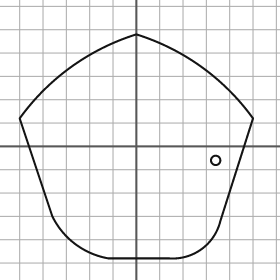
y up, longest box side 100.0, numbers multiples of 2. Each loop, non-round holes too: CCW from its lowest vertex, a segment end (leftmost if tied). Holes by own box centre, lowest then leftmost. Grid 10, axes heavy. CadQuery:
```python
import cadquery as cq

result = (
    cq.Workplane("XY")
    .moveTo(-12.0, -48.0)
    .lineTo(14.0, -48.0)
    .threePointArc((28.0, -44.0), (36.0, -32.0))
    .lineTo(50.0, 12.0)
    .threePointArc((28.0, 34.0), (0.0, 48.0))
    .threePointArc((-28.0, 34.0), (-50.0, 12.0))
    .lineTo(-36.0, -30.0)
    .threePointArc((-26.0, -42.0), (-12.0, -48.0))
    .close()
    .moveTo(34.0, -6.0)
    .circle(2.0)
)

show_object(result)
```